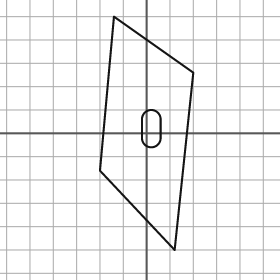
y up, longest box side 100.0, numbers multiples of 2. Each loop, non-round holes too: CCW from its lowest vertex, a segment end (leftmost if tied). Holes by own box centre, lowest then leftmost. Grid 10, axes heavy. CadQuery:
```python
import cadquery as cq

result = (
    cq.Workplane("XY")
    .moveTo(12.0, -50.0)
    .lineTo(20.0, 26.0)
    .lineTo(-14.0, 50.0)
    .lineTo(-20.0, -16.0)
    .close()
    .moveTo(-2.0, -2.0)
    .threePointArc((2.0, -6.0), (6.0, -2.0))
    .lineTo(6.0, 6.0)
    .threePointArc((2.0, 10.0), (-2.0, 6.0))
    .close()
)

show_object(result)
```